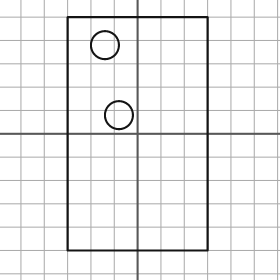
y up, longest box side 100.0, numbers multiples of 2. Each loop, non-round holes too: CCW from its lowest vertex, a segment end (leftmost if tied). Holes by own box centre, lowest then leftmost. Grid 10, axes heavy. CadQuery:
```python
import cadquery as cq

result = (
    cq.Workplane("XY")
    .moveTo(-30.0, -50.0)
    .lineTo(30.0, -50.0)
    .lineTo(30.0, 50.0)
    .lineTo(-30.0, 50.0)
    .close()
    .moveTo(-8.0, 8.0)
    .circle(6.0)
    .moveTo(-14.0, 38.0)
    .circle(6.0)
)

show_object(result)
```